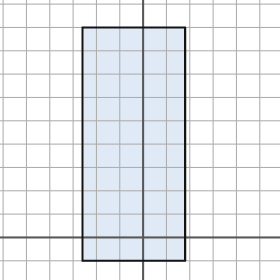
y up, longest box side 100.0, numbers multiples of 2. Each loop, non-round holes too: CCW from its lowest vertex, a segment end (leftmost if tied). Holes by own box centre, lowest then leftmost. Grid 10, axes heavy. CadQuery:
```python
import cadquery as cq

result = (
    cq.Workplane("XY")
    .moveTo(-26.0, -10.0)
    .lineTo(18.0, -10.0)
    .lineTo(18.0, 90.0)
    .lineTo(-26.0, 90.0)
    .close()
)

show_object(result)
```